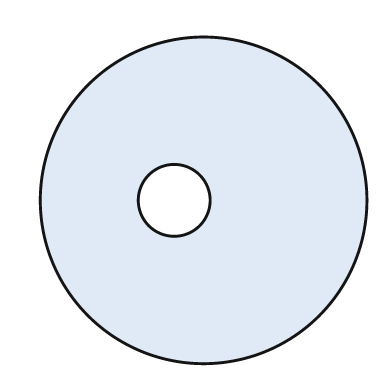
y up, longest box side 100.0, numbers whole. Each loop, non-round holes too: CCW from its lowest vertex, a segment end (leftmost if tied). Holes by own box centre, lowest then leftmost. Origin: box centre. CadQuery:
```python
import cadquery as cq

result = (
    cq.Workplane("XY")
    .moveTo(0.0, 0.0)
    .circle(50.0)
    .moveTo(-9.0, 0.0)
    .circle(11.0)
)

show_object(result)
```